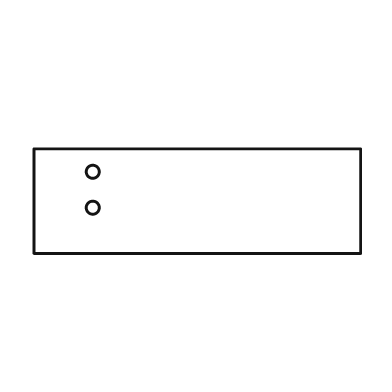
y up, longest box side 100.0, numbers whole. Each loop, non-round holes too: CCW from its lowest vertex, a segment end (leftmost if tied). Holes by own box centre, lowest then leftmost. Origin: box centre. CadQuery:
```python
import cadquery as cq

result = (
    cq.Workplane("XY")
    .moveTo(-50.0, -16.0)
    .lineTo(50.0, -16.0)
    .lineTo(50.0, 16.0)
    .lineTo(-50.0, 16.0)
    .close()
    .moveTo(-32.0, -2.0)
    .circle(2.0)
    .moveTo(-32.0, 9.0)
    .circle(2.0)
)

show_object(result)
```